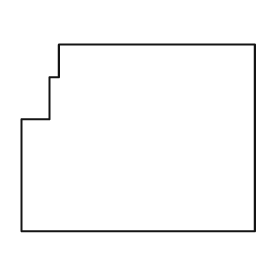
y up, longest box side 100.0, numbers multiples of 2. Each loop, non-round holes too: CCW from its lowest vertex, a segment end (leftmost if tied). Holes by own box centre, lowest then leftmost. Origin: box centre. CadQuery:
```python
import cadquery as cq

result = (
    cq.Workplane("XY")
    .moveTo(-50.0, -40.0)
    .lineTo(50.0, -40.0)
    .lineTo(50.0, 40.0)
    .lineTo(-34.0, 40.0)
    .lineTo(-34.0, 26.0)
    .lineTo(-38.0, 26.0)
    .lineTo(-38.0, 8.0)
    .lineTo(-50.0, 8.0)
    .close()
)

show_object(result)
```